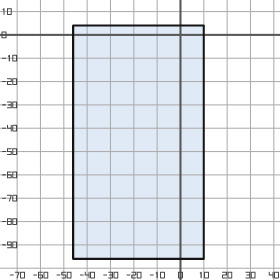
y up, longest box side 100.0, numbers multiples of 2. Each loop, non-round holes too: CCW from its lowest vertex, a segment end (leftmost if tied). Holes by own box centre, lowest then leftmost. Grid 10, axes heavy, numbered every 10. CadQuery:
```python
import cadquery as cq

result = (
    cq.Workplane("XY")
    .moveTo(-46.0, -96.0)
    .lineTo(10.0, -96.0)
    .lineTo(10.0, 4.0)
    .lineTo(-46.0, 4.0)
    .close()
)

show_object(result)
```